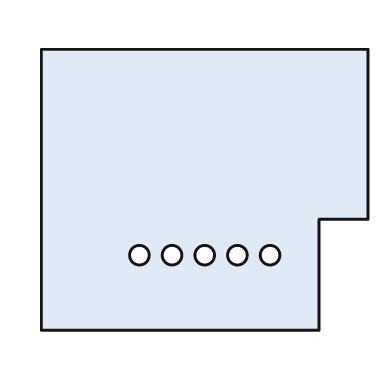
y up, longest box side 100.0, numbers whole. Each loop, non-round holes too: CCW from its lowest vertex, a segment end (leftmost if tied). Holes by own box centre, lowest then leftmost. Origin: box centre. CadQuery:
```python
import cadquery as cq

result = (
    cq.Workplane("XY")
    .moveTo(-50.0, -43.0)
    .lineTo(35.0, -43.0)
    .lineTo(35.0, -9.0)
    .lineTo(50.0, -9.0)
    .lineTo(50.0, 43.0)
    .lineTo(-50.0, 43.0)
    .close()
    .moveTo(-20.0, -20.0)
    .circle(3.0)
    .moveTo(-10.0, -20.0)
    .circle(3.0)
    .moveTo(0.0, -20.0)
    .circle(3.0)
    .moveTo(10.0, -20.0)
    .circle(3.0)
    .moveTo(20.0, -20.0)
    .circle(3.0)
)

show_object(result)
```